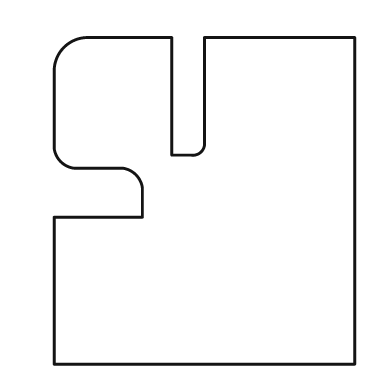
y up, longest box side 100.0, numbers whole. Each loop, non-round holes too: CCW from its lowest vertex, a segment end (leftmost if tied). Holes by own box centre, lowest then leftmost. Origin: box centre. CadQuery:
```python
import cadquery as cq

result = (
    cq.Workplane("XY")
    .moveTo(-46.0, -50.0)
    .lineTo(46.0, -50.0)
    .lineTo(46.0, 50.0)
    .lineTo(0.0, 50.0)
    .lineTo(0.0, 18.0)
    .threePointArc((-1.0, 15.0), (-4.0, 14.0))
    .lineTo(-10.0, 14.0)
    .lineTo(-10.0, 50.0)
    .lineTo(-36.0, 50.0)
    .threePointArc((-43.0, 47.0), (-46.0, 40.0))
    .lineTo(-46.0, 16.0)
    .threePointArc((-44.0, 12.0), (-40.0, 10.0))
    .lineTo(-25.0, 10.0)
    .threePointArc((-21.0, 8.0), (-19.0, 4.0))
    .lineTo(-19.0, -5.0)
    .lineTo(-46.0, -5.0)
    .close()
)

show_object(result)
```